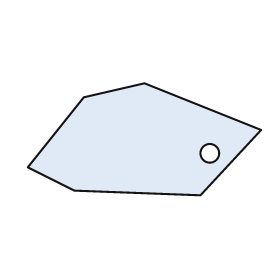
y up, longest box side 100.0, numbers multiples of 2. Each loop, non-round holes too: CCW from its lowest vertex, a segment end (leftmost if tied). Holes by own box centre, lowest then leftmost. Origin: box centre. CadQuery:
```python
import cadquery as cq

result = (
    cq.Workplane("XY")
    .moveTo(24.0, -24.0)
    .lineTo(50.0, 4.0)
    .lineTo(0.0, 24.0)
    .lineTo(-26.0, 18.0)
    .lineTo(-50.0, -12.0)
    .lineTo(-30.0, -22.0)
    .close()
    .moveTo(28.0, -6.0)
    .circle(4.0)
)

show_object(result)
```